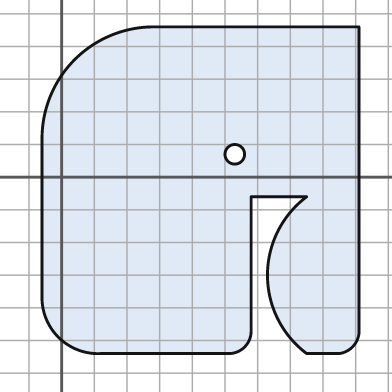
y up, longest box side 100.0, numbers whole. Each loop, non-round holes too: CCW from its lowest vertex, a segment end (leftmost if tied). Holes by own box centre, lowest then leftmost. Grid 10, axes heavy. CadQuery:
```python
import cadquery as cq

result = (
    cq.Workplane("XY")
    .moveTo(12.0, -54.0)
    .lineTo(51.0, -54.0)
    .threePointArc((56.0, -52.0), (58.0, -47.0))
    .lineTo(58.0, -6.0)
    .lineTo(75.0, -6.0)
    .threePointArc((63.0, -30.0), (75.0, -54.0))
    .lineTo(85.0, -54.0)
    .threePointArc((89.0, -52.0), (91.0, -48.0))
    .lineTo(91.0, 46.0)
    .lineTo(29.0, 46.0)
    .threePointArc((4.0, 36.0), (-6.0, 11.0))
    .lineTo(-6.0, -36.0)
    .threePointArc((-1.0, -49.0), (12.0, -54.0))
    .close()
    .moveTo(53.0, 7.0)
    .circle(3.0)
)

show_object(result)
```